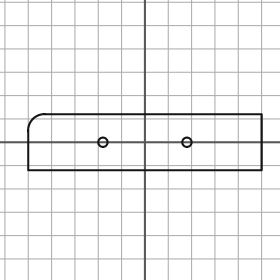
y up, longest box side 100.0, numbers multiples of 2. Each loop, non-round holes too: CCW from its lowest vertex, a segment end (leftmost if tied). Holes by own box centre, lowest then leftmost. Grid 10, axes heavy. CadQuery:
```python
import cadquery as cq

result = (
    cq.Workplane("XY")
    .moveTo(-50.0, -12.0)
    .lineTo(50.0, -12.0)
    .lineTo(50.0, 12.0)
    .lineTo(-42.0, 12.0)
    .threePointArc((-48.0, 10.0), (-50.0, 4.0))
    .close()
    .moveTo(-18.0, 0.0)
    .circle(2.0)
    .moveTo(18.0, 0.0)
    .circle(2.0)
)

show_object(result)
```